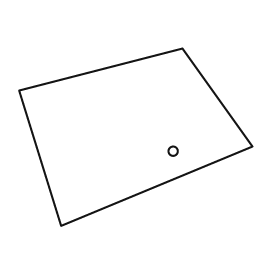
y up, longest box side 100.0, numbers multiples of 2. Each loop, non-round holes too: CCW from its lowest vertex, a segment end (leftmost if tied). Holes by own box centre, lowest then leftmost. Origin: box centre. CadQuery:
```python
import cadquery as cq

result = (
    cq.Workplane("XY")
    .moveTo(-32.0, -38.0)
    .lineTo(50.0, -4.0)
    .lineTo(20.0, 38.0)
    .lineTo(-50.0, 20.0)
    .close()
    .moveTo(16.0, -6.0)
    .circle(2.0)
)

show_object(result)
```